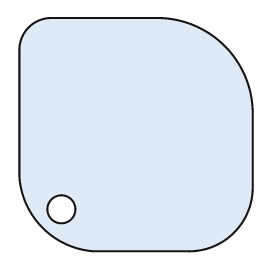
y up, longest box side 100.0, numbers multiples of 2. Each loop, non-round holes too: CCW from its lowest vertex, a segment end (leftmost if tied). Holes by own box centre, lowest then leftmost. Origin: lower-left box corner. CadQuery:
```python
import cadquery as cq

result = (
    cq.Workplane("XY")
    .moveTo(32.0, 0.0)
    .lineTo(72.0, 0.0)
    .threePointArc((92.0, 8.0), (100.0, 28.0))
    .lineTo(100.0, 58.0)
    .threePointArc((88.0, 88.0), (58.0, 100.0))
    .lineTo(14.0, 100.0)
    .threePointArc((4.0, 96.0), (0.0, 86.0))
    .lineTo(0.0, 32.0)
    .threePointArc((10.0, 10.0), (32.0, 0.0))
    .close()
    .moveTo(18.0, 18.0)
    .circle(6.0)
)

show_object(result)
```